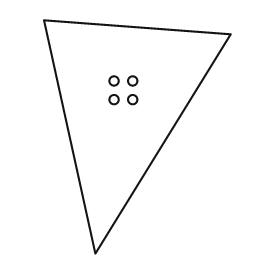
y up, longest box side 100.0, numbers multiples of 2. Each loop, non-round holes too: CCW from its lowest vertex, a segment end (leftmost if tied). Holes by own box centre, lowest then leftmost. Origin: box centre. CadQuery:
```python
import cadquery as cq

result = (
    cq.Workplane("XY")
    .moveTo(-18.0, -50.0)
    .lineTo(40.0, 44.0)
    .lineTo(-40.0, 50.0)
    .close()
    .moveTo(-10.0, 16.0)
    .circle(2.0)
    .moveTo(-2.0, 16.0)
    .circle(2.0)
    .moveTo(-10.0, 24.0)
    .circle(2.0)
    .moveTo(-2.0, 24.0)
    .circle(2.0)
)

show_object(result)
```